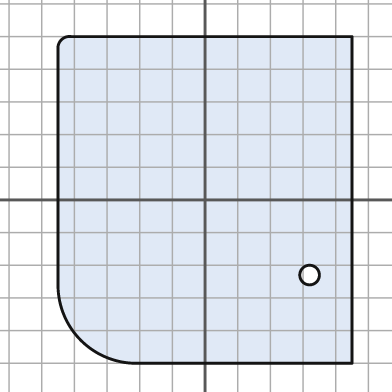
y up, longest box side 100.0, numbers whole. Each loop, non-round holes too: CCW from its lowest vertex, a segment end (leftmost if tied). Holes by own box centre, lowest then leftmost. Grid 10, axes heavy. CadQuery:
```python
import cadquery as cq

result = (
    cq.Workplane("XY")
    .moveTo(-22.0, -50.0)
    .lineTo(45.0, -50.0)
    .lineTo(45.0, 50.0)
    .lineTo(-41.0, 50.0)
    .threePointArc((-44.0, 49.0), (-45.0, 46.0))
    .lineTo(-45.0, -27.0)
    .threePointArc((-38.0, -43.0), (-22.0, -50.0))
    .close()
    .moveTo(32.0, -23.0)
    .circle(3.0)
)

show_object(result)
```